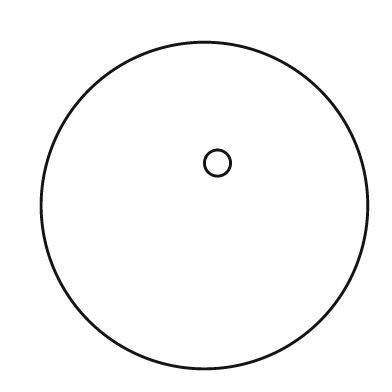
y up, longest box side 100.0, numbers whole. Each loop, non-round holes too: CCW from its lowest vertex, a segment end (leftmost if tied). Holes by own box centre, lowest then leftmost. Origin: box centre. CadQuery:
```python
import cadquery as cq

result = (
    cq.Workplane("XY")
    .moveTo(0.0, 0.0)
    .circle(50.0)
    .moveTo(4.0, 13.0)
    .circle(4.0)
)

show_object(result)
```